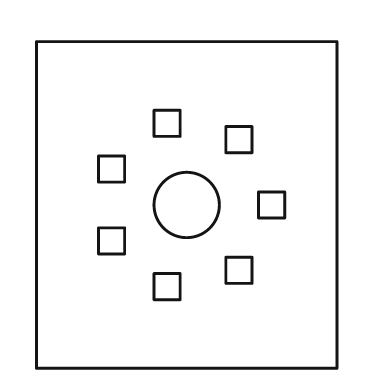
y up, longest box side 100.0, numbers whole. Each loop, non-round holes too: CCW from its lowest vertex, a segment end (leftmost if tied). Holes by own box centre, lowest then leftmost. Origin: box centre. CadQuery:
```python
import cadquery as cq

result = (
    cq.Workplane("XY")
    .moveTo(-46.0, -50.0)
    .lineTo(46.0, -50.0)
    .lineTo(46.0, 50.0)
    .lineTo(-46.0, 50.0)
    .close()
    .moveTo(-10.0, -29.0)
    .lineTo(-2.0, -29.0)
    .lineTo(-2.0, -21.0)
    .lineTo(-10.0, -21.0)
    .close()
    .moveTo(12.0, -24.0)
    .lineTo(20.0, -24.0)
    .lineTo(20.0, -16.0)
    .lineTo(12.0, -16.0)
    .close()
    .moveTo(-27.0, -15.0)
    .lineTo(-19.0, -15.0)
    .lineTo(-19.0, -7.0)
    .lineTo(-27.0, -7.0)
    .close()
    .moveTo(0.0, 0.0)
    .circle(10.0)
    .moveTo(22.0, -4.0)
    .lineTo(30.0, -4.0)
    .lineTo(30.0, 4.0)
    .lineTo(22.0, 4.0)
    .close()
    .moveTo(-27.0, 7.0)
    .lineTo(-19.0, 7.0)
    .lineTo(-19.0, 15.0)
    .lineTo(-27.0, 15.0)
    .close()
    .moveTo(12.0, 16.0)
    .lineTo(20.0, 16.0)
    .lineTo(20.0, 24.0)
    .lineTo(12.0, 24.0)
    .close()
    .moveTo(-10.0, 21.0)
    .lineTo(-2.0, 21.0)
    .lineTo(-2.0, 29.0)
    .lineTo(-10.0, 29.0)
    .close()
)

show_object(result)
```